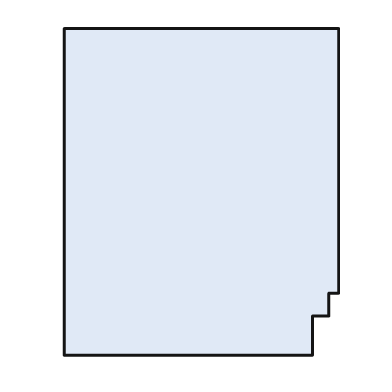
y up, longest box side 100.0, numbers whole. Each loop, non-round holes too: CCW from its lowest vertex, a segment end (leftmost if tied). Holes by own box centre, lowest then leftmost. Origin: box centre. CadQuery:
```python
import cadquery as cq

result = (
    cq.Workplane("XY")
    .moveTo(-42.0, -50.0)
    .lineTo(34.0, -50.0)
    .lineTo(34.0, -38.0)
    .lineTo(39.0, -38.0)
    .lineTo(39.0, -31.0)
    .lineTo(42.0, -31.0)
    .lineTo(42.0, 50.0)
    .lineTo(-42.0, 50.0)
    .close()
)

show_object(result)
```